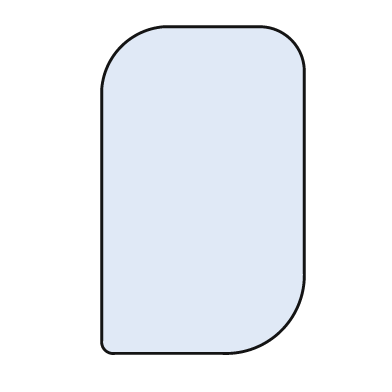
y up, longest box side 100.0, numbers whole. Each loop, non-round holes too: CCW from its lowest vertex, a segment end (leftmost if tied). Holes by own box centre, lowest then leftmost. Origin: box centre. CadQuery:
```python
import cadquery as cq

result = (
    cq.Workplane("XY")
    .moveTo(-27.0, -50.0)
    .lineTo(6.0, -50.0)
    .threePointArc((24.0, -43.0), (31.0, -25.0))
    .lineTo(31.0, 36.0)
    .threePointArc((27.0, 46.0), (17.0, 50.0))
    .lineTo(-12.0, 50.0)
    .threePointArc((-25.0, 44.0), (-31.0, 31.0))
    .lineTo(-31.0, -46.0)
    .threePointArc((-30.0, -49.0), (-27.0, -50.0))
    .close()
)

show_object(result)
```